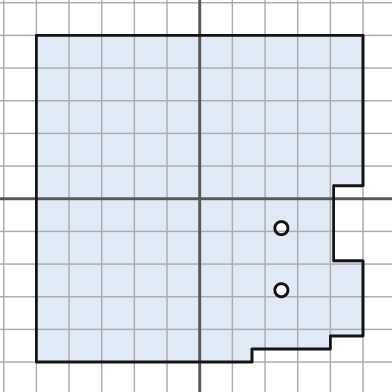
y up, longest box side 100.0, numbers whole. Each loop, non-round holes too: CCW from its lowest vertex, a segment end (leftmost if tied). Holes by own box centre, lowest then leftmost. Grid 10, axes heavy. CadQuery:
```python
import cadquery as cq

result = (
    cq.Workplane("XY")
    .moveTo(-50.0, -50.0)
    .lineTo(16.0, -50.0)
    .lineTo(16.0, -46.0)
    .lineTo(40.0, -46.0)
    .lineTo(40.0, -42.0)
    .lineTo(50.0, -42.0)
    .lineTo(50.0, -19.0)
    .lineTo(41.0, -19.0)
    .lineTo(41.0, 4.0)
    .lineTo(50.0, 4.0)
    .lineTo(50.0, 50.0)
    .lineTo(-50.0, 50.0)
    .close()
    .moveTo(25.0, -28.0)
    .circle(2.0)
    .moveTo(25.0, -9.0)
    .circle(2.0)
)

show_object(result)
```